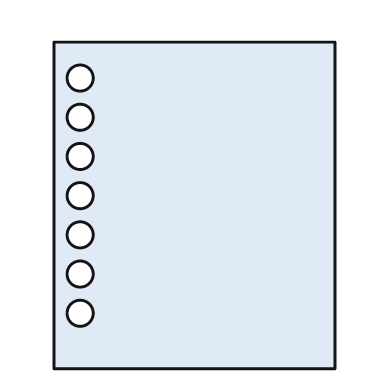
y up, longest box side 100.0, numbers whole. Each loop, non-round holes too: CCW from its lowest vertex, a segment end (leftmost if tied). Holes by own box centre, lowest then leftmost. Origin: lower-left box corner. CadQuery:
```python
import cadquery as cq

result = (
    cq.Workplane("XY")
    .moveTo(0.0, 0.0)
    .lineTo(86.0, 0.0)
    .lineTo(86.0, 100.0)
    .lineTo(0.0, 100.0)
    .close()
    .moveTo(8.0, 17.0)
    .circle(4.0)
    .moveTo(8.0, 29.0)
    .circle(4.0)
    .moveTo(8.0, 41.0)
    .circle(4.0)
    .moveTo(8.0, 53.0)
    .circle(4.0)
    .moveTo(8.0, 65.0)
    .circle(4.0)
    .moveTo(8.0, 77.0)
    .circle(4.0)
    .moveTo(8.0, 89.0)
    .circle(4.0)
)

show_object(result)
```